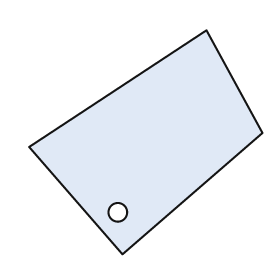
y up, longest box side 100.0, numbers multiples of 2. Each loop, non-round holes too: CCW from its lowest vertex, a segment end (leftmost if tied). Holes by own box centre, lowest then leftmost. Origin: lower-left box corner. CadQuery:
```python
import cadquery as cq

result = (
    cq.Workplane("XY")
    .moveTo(40.0, 0.0)
    .lineTo(100.0, 52.0)
    .lineTo(76.0, 96.0)
    .lineTo(0.0, 46.0)
    .close()
    .moveTo(38.0, 18.0)
    .circle(4.0)
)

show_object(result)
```